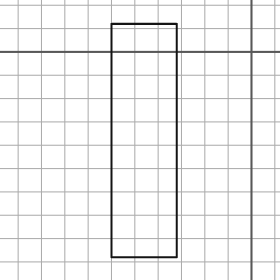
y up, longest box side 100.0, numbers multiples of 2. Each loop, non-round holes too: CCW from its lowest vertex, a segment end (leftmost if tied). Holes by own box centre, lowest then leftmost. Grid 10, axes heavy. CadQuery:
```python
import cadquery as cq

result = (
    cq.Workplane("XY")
    .moveTo(-60.0, -88.0)
    .lineTo(-32.0, -88.0)
    .lineTo(-32.0, 12.0)
    .lineTo(-60.0, 12.0)
    .close()
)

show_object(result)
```